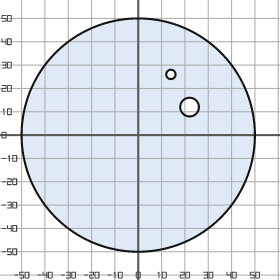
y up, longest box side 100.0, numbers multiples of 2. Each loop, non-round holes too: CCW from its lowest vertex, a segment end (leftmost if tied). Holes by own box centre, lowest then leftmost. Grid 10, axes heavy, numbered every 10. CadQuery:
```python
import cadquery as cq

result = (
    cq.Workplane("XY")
    .moveTo(0.0, 0.0)
    .circle(50.0)
    .moveTo(22.0, 12.0)
    .circle(4.0)
    .moveTo(14.0, 26.0)
    .circle(2.0)
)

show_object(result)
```